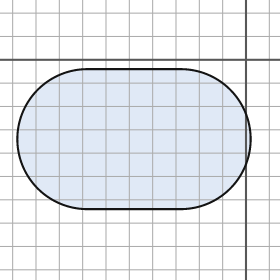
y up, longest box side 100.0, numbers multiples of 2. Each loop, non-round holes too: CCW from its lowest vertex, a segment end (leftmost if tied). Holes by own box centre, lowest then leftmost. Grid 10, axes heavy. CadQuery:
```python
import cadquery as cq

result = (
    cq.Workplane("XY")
    .moveTo(-68.0, -64.0)
    .lineTo(-28.0, -64.0)
    .threePointArc((2.0, -34.0), (-28.0, -4.0))
    .lineTo(-68.0, -4.0)
    .threePointArc((-98.0, -34.0), (-68.0, -64.0))
    .close()
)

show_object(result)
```